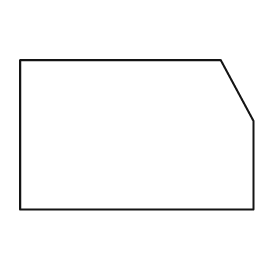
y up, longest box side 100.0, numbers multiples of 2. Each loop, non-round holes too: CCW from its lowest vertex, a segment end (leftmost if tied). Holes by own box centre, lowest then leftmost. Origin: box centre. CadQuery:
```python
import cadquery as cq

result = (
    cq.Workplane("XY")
    .moveTo(-50.0, -32.0)
    .lineTo(50.0, -32.0)
    .lineTo(50.0, 6.0)
    .lineTo(36.0, 32.0)
    .lineTo(-50.0, 32.0)
    .close()
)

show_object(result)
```